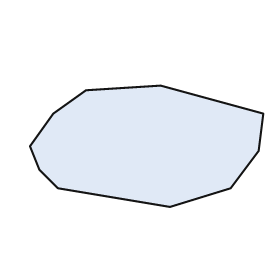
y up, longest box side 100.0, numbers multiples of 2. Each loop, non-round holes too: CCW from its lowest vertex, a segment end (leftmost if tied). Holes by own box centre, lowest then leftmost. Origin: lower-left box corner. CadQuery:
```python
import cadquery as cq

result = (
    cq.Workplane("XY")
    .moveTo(60.0, 0.0)
    .lineTo(86.0, 8.0)
    .lineTo(98.0, 24.0)
    .lineTo(100.0, 40.0)
    .lineTo(56.0, 52.0)
    .lineTo(24.0, 50.0)
    .lineTo(10.0, 40.0)
    .lineTo(0.0, 26.0)
    .lineTo(4.0, 16.0)
    .lineTo(12.0, 8.0)
    .close()
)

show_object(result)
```